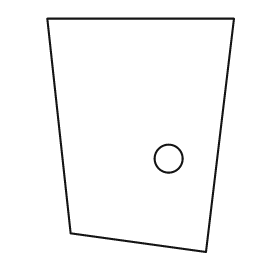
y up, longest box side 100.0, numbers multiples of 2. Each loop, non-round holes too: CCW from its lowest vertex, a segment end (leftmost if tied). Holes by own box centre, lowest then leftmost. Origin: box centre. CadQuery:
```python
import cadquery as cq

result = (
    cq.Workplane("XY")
    .moveTo(28.0, -50.0)
    .lineTo(40.0, 50.0)
    .lineTo(-40.0, 50.0)
    .lineTo(-30.0, -42.0)
    .close()
    .moveTo(12.0, -10.0)
    .circle(6.0)
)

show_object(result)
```